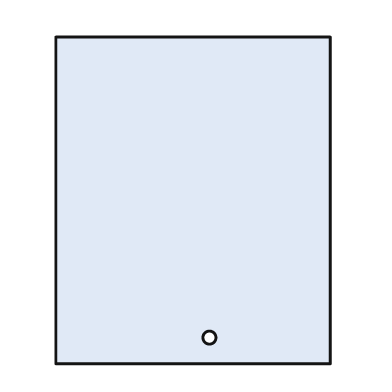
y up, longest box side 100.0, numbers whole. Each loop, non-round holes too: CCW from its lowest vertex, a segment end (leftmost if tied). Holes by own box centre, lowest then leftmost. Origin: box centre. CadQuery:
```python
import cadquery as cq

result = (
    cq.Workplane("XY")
    .moveTo(-42.0, -50.0)
    .lineTo(42.0, -50.0)
    .lineTo(42.0, 50.0)
    .lineTo(-42.0, 50.0)
    .close()
    .moveTo(5.0, -42.0)
    .circle(2.0)
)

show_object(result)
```